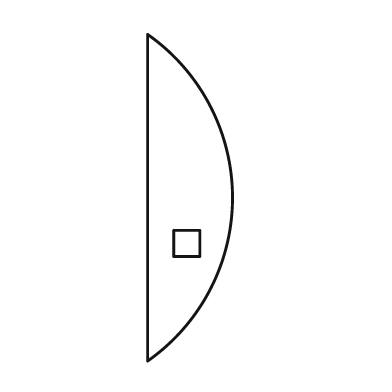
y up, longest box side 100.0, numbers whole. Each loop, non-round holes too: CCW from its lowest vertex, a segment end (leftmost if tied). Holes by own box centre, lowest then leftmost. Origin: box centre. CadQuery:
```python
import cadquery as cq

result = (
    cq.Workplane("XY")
    .moveTo(-13.0, -50.0)
    .threePointArc((13.0, 0.0), (-13.0, 50.0))
    .close()
    .moveTo(-5.0, -18.0)
    .lineTo(3.0, -18.0)
    .lineTo(3.0, -10.0)
    .lineTo(-5.0, -10.0)
    .close()
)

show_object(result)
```